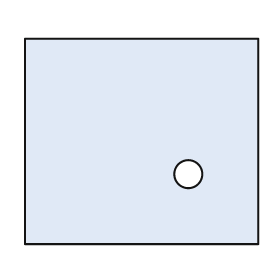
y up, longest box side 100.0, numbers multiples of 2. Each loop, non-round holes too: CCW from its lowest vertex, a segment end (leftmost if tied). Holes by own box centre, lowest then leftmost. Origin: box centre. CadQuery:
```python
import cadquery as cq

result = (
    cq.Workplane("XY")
    .moveTo(-50.0, -44.0)
    .lineTo(50.0, -44.0)
    .lineTo(50.0, 44.0)
    .lineTo(-50.0, 44.0)
    .close()
    .moveTo(20.0, -14.0)
    .circle(6.0)
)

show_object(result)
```